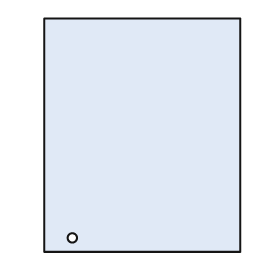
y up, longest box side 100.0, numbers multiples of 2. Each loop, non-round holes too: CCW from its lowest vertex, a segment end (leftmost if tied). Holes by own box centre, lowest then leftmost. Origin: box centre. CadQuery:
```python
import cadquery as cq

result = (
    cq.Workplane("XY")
    .moveTo(-42.0, -50.0)
    .lineTo(42.0, -50.0)
    .lineTo(42.0, 50.0)
    .lineTo(-42.0, 50.0)
    .close()
    .moveTo(-30.0, -44.0)
    .circle(2.0)
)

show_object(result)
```